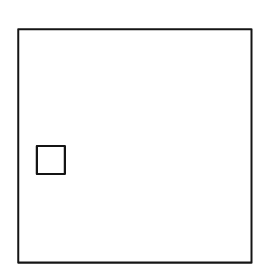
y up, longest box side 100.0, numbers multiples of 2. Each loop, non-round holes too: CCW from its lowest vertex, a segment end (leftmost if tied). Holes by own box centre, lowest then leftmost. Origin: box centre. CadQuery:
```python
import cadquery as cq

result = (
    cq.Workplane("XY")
    .moveTo(-50.0, -50.0)
    .lineTo(50.0, -50.0)
    .lineTo(50.0, 50.0)
    .lineTo(-50.0, 50.0)
    .close()
    .moveTo(-42.0, -12.0)
    .lineTo(-30.0, -12.0)
    .lineTo(-30.0, 0.0)
    .lineTo(-42.0, 0.0)
    .close()
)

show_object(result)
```